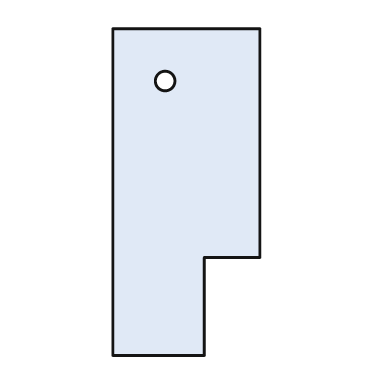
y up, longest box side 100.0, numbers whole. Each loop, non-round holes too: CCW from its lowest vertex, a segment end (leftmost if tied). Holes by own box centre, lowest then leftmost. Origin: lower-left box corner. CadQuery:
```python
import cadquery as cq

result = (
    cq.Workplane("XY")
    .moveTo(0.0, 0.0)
    .lineTo(28.0, 0.0)
    .lineTo(28.0, 30.0)
    .lineTo(45.0, 30.0)
    .lineTo(45.0, 100.0)
    .lineTo(0.0, 100.0)
    .close()
    .moveTo(16.0, 84.0)
    .circle(3.0)
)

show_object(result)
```